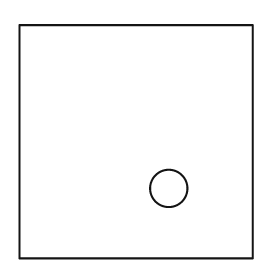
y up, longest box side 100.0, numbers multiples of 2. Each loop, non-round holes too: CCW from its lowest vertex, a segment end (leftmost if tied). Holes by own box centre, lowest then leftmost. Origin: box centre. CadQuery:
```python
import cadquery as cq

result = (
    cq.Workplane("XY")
    .moveTo(-50.0, -50.0)
    .lineTo(50.0, -50.0)
    .lineTo(50.0, 50.0)
    .lineTo(-50.0, 50.0)
    .close()
    .moveTo(14.0, -20.0)
    .circle(8.0)
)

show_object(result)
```